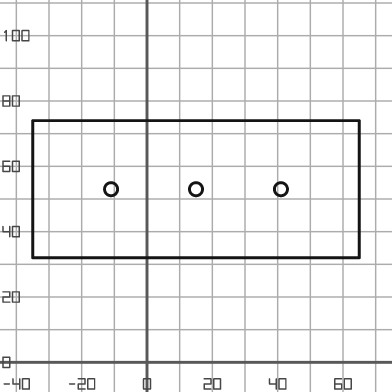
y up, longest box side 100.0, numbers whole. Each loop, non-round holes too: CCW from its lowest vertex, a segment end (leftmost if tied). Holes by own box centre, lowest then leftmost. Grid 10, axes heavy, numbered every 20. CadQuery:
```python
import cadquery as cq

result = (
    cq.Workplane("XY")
    .moveTo(-35.0, 32.0)
    .lineTo(65.0, 32.0)
    .lineTo(65.0, 74.0)
    .lineTo(-35.0, 74.0)
    .close()
    .moveTo(-11.0, 53.0)
    .circle(2.0)
    .moveTo(15.0, 53.0)
    .circle(2.0)
    .moveTo(41.0, 53.0)
    .circle(2.0)
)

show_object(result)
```